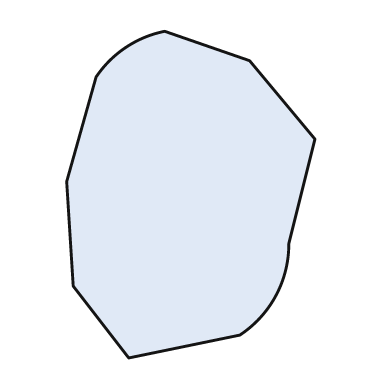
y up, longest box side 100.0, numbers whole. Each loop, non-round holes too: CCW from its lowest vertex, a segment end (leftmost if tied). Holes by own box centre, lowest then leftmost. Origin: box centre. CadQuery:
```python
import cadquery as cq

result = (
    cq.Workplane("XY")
    .moveTo(-19.0, -50.0)
    .lineTo(15.0, -43.0)
    .threePointArc((26.0, -31.0), (30.0, -15.0))
    .lineTo(38.0, 17.0)
    .lineTo(18.0, 41.0)
    .lineTo(-8.0, 50.0)
    .threePointArc((-20.0, 45.0), (-29.0, 36.0))
    .lineTo(-38.0, 4.0)
    .lineTo(-36.0, -28.0)
    .close()
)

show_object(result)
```